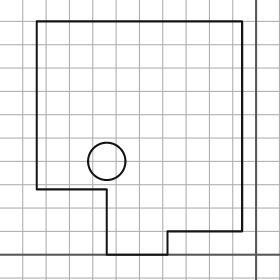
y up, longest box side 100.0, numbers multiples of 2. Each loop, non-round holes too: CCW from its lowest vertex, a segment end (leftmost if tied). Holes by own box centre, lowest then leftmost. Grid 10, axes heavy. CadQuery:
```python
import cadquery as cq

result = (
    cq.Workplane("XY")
    .moveTo(-64.0, 0.0)
    .lineTo(-38.0, 0.0)
    .lineTo(-38.0, 10.0)
    .lineTo(-6.0, 10.0)
    .lineTo(-6.0, 100.0)
    .lineTo(-94.0, 100.0)
    .lineTo(-94.0, 28.0)
    .lineTo(-64.0, 28.0)
    .close()
    .moveTo(-64.0, 40.0)
    .circle(8.0)
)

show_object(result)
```